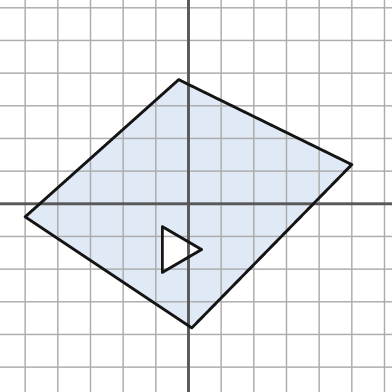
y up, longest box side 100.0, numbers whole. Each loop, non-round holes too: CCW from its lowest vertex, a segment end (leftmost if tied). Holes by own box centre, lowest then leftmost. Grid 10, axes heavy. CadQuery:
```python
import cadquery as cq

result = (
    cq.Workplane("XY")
    .moveTo(1.0, -38.0)
    .lineTo(50.0, 12.0)
    .lineTo(-3.0, 38.0)
    .lineTo(-50.0, -4.0)
    .close()
    .moveTo(-8.0, -21.0)
    .lineTo(4.0, -14.0)
    .lineTo(-8.0, -7.0)
    .close()
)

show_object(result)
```